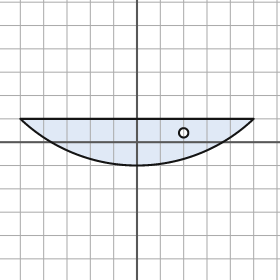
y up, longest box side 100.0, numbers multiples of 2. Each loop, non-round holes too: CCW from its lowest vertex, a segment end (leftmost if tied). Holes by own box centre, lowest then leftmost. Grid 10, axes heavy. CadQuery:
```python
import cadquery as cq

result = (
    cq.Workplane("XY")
    .moveTo(-50.0, 10.0)
    .threePointArc((0.0, -10.0), (50.0, 10.0))
    .close()
    .moveTo(20.0, 4.0)
    .circle(2.0)
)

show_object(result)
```